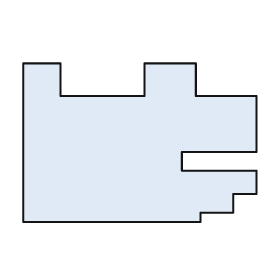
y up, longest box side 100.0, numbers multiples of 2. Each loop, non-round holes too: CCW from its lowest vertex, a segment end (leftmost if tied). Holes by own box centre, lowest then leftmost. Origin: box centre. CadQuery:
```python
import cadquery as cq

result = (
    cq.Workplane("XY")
    .moveTo(-50.0, -34.0)
    .lineTo(26.0, -34.0)
    .lineTo(26.0, -30.0)
    .lineTo(40.0, -30.0)
    .lineTo(40.0, -22.0)
    .lineTo(50.0, -22.0)
    .lineTo(50.0, -12.0)
    .lineTo(18.0, -12.0)
    .lineTo(18.0, -4.0)
    .lineTo(50.0, -4.0)
    .lineTo(50.0, 20.0)
    .lineTo(24.0, 20.0)
    .lineTo(24.0, 34.0)
    .lineTo(2.0, 34.0)
    .lineTo(2.0, 20.0)
    .lineTo(-34.0, 20.0)
    .lineTo(-34.0, 34.0)
    .lineTo(-50.0, 34.0)
    .close()
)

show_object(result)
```